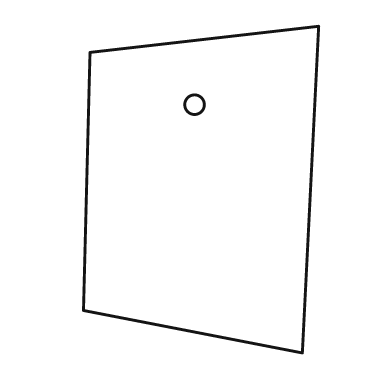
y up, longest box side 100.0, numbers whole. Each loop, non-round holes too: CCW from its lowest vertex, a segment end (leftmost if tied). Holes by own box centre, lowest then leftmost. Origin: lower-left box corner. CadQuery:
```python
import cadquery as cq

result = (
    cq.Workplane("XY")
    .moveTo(67.0, 0.0)
    .lineTo(72.0, 100.0)
    .lineTo(2.0, 92.0)
    .lineTo(0.0, 13.0)
    .close()
    .moveTo(34.0, 76.0)
    .circle(3.0)
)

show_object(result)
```